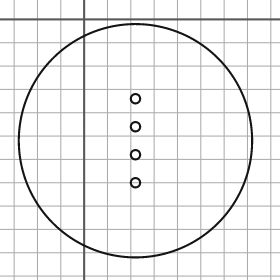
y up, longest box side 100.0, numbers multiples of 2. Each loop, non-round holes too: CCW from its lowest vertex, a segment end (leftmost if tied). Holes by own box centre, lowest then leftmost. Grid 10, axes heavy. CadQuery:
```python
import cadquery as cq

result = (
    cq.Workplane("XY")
    .moveTo(22.0, -52.0)
    .circle(50.0)
    .moveTo(22.0, -70.0)
    .circle(2.0)
    .moveTo(22.0, -58.0)
    .circle(2.0)
    .moveTo(22.0, -46.0)
    .circle(2.0)
    .moveTo(22.0, -34.0)
    .circle(2.0)
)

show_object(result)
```